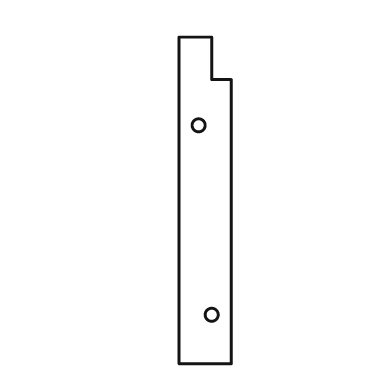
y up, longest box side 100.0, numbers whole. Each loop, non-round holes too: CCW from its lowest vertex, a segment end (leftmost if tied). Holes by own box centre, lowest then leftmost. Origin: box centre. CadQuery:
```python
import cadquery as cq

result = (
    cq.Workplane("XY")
    .moveTo(-8.0, -50.0)
    .lineTo(8.0, -50.0)
    .lineTo(8.0, 37.0)
    .lineTo(2.0, 37.0)
    .lineTo(2.0, 50.0)
    .lineTo(-8.0, 50.0)
    .close()
    .moveTo(2.0, -35.0)
    .circle(2.0)
    .moveTo(-2.0, 23.0)
    .circle(2.0)
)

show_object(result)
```